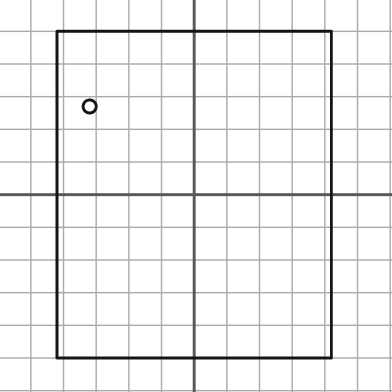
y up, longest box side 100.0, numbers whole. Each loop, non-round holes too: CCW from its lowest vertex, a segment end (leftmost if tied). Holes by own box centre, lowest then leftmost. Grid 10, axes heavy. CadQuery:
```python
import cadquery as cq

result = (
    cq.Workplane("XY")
    .moveTo(-42.0, -50.0)
    .lineTo(42.0, -50.0)
    .lineTo(42.0, 50.0)
    .lineTo(-42.0, 50.0)
    .close()
    .moveTo(-32.0, 27.0)
    .circle(2.0)
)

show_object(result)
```